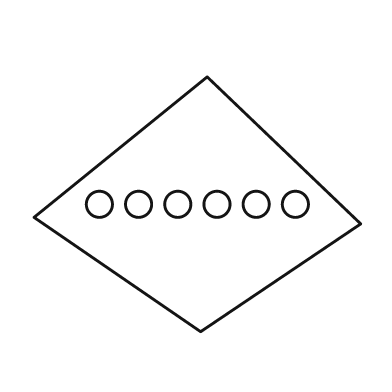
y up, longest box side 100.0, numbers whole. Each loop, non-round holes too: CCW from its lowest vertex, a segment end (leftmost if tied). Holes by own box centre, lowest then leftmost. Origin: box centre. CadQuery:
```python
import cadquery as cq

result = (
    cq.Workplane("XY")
    .moveTo(1.0, -39.0)
    .lineTo(50.0, -6.0)
    .lineTo(3.0, 39.0)
    .lineTo(-50.0, -4.0)
    .close()
    .moveTo(-30.0, 0.0)
    .circle(4.0)
    .moveTo(-18.0, 0.0)
    .circle(4.0)
    .moveTo(-6.0, 0.0)
    .circle(4.0)
    .moveTo(6.0, 0.0)
    .circle(4.0)
    .moveTo(18.0, 0.0)
    .circle(4.0)
    .moveTo(30.0, 0.0)
    .circle(4.0)
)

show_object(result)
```